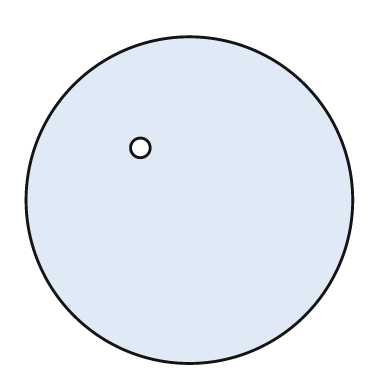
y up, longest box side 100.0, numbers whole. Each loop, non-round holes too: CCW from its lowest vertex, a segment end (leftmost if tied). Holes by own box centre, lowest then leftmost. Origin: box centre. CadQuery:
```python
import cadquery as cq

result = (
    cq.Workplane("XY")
    .moveTo(0.0, 0.0)
    .circle(50.0)
    .moveTo(-15.0, 16.0)
    .circle(3.0)
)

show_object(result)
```